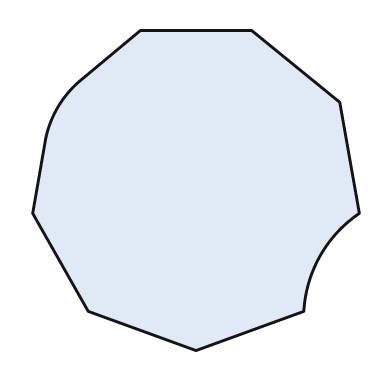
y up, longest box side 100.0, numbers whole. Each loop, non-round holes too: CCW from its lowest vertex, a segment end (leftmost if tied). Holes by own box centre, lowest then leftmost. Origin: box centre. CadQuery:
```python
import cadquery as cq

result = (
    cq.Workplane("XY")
    .moveTo(0.0, -49.0)
    .lineTo(33.0, -37.0)
    .threePointArc((38.0, -20.0), (50.0, -7.0))
    .lineTo(44.0, 27.0)
    .lineTo(17.0, 49.0)
    .lineTo(-17.0, 49.0)
    .lineTo(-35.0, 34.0)
    .threePointArc((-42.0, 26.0), (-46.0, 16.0))
    .lineTo(-50.0, -7.0)
    .lineTo(-33.0, -37.0)
    .close()
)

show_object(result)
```